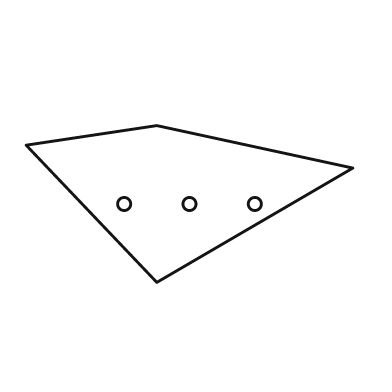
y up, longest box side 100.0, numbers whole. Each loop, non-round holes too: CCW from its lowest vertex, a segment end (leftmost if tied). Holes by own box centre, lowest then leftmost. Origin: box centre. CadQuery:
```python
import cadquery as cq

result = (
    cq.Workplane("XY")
    .moveTo(-10.0, -24.0)
    .lineTo(50.0, 11.0)
    .lineTo(-10.0, 24.0)
    .lineTo(-50.0, 18.0)
    .close()
    .moveTo(-20.0, 0.0)
    .circle(2.0)
    .moveTo(0.0, 0.0)
    .circle(2.0)
    .moveTo(20.0, 0.0)
    .circle(2.0)
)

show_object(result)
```